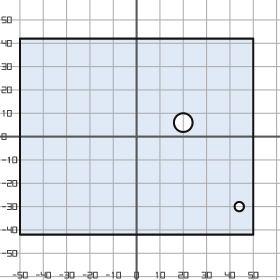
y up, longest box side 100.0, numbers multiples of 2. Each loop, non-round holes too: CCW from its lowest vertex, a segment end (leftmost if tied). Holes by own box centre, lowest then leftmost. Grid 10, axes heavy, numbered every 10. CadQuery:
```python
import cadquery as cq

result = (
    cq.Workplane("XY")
    .moveTo(-50.0, -42.0)
    .lineTo(50.0, -42.0)
    .lineTo(50.0, 42.0)
    .lineTo(-50.0, 42.0)
    .close()
    .moveTo(44.0, -30.0)
    .circle(2.0)
    .moveTo(20.0, 6.0)
    .circle(4.0)
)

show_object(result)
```